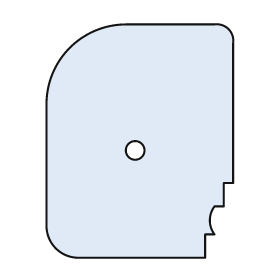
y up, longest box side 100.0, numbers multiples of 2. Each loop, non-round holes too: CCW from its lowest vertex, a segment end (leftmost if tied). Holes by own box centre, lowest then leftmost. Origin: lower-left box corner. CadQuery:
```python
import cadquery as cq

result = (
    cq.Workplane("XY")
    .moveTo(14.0, 0.0)
    .lineTo(68.0, 0.0)
    .lineTo(68.0, 10.0)
    .lineTo(72.0, 10.0)
    .threePointArc((70.0, 16.0), (72.0, 22.0))
    .lineTo(76.0, 22.0)
    .lineTo(76.0, 32.0)
    .lineTo(80.0, 32.0)
    .lineTo(80.0, 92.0)
    .threePointArc((78.0, 98.0), (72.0, 100.0))
    .lineTo(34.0, 100.0)
    .threePointArc((10.0, 90.0), (0.0, 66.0))
    .lineTo(0.0, 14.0)
    .threePointArc((4.0, 4.0), (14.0, 0.0))
    .close()
    .moveTo(38.0, 46.0)
    .circle(4.0)
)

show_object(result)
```